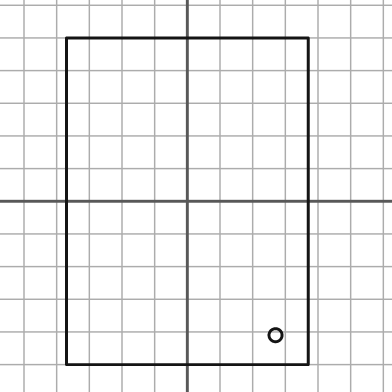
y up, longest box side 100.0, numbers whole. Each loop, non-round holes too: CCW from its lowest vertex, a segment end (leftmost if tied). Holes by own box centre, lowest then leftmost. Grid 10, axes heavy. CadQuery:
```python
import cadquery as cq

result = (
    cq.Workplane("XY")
    .moveTo(-37.0, -50.0)
    .lineTo(37.0, -50.0)
    .lineTo(37.0, 50.0)
    .lineTo(-37.0, 50.0)
    .close()
    .moveTo(27.0, -41.0)
    .circle(2.0)
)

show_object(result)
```